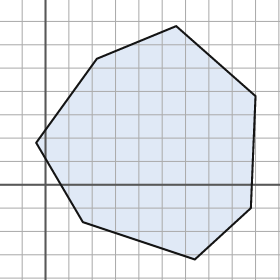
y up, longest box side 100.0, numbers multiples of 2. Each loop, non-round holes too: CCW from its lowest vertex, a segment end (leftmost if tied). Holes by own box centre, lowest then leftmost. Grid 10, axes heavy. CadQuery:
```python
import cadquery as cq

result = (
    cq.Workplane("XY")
    .moveTo(64.0, -32.0)
    .lineTo(88.0, -10.0)
    .lineTo(90.0, 38.0)
    .lineTo(56.0, 68.0)
    .lineTo(22.0, 54.0)
    .lineTo(-4.0, 18.0)
    .lineTo(16.0, -16.0)
    .close()
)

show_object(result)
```